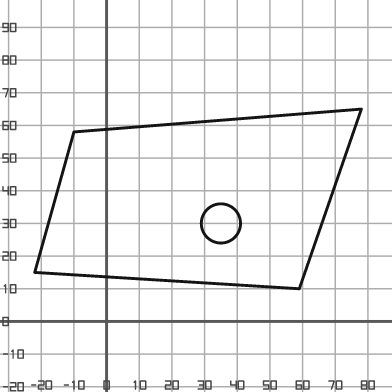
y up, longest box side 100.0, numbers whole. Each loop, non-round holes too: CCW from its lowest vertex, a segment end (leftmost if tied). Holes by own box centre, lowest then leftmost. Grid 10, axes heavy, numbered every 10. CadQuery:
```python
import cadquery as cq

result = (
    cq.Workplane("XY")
    .moveTo(59.0, 10.0)
    .lineTo(78.0, 65.0)
    .lineTo(-10.0, 58.0)
    .lineTo(-22.0, 15.0)
    .close()
    .moveTo(35.0, 30.0)
    .circle(6.0)
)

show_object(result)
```